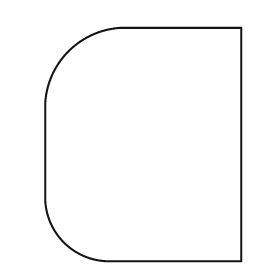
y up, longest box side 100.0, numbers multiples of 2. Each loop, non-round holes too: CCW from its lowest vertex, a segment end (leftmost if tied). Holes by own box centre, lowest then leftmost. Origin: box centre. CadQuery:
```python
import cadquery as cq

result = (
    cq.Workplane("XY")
    .moveTo(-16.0, -50.0)
    .lineTo(42.0, -50.0)
    .lineTo(42.0, 50.0)
    .lineTo(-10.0, 50.0)
    .threePointArc((-32.0, 40.0), (-42.0, 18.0))
    .lineTo(-42.0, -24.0)
    .threePointArc((-34.0, -42.0), (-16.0, -50.0))
    .close()
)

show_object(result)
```